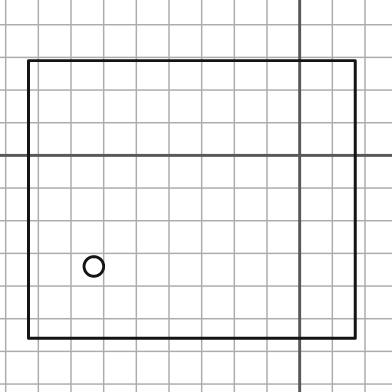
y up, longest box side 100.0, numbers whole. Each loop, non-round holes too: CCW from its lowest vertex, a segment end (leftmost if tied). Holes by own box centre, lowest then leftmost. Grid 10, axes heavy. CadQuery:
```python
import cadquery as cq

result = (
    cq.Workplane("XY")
    .moveTo(-83.0, -56.0)
    .lineTo(17.0, -56.0)
    .lineTo(17.0, 29.0)
    .lineTo(-83.0, 29.0)
    .close()
    .moveTo(-63.0, -34.0)
    .circle(3.0)
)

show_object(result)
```